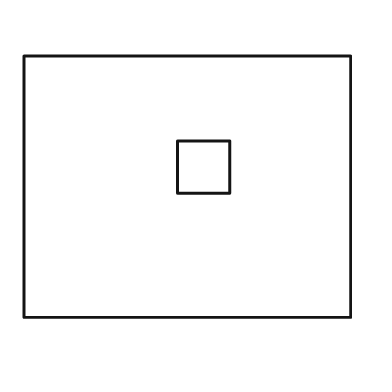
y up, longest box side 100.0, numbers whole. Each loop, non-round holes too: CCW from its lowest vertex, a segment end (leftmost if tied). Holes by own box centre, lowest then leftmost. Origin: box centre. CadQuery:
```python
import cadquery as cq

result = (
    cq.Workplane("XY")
    .moveTo(-50.0, -40.0)
    .lineTo(50.0, -40.0)
    .lineTo(50.0, 40.0)
    .lineTo(-50.0, 40.0)
    .close()
    .moveTo(-3.0, -2.0)
    .lineTo(13.0, -2.0)
    .lineTo(13.0, 14.0)
    .lineTo(-3.0, 14.0)
    .close()
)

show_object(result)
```